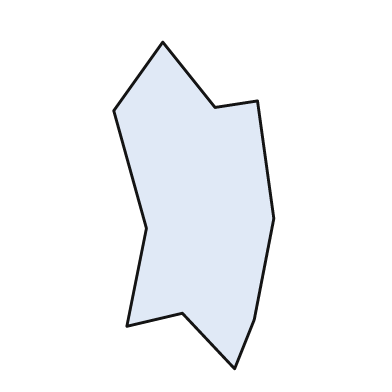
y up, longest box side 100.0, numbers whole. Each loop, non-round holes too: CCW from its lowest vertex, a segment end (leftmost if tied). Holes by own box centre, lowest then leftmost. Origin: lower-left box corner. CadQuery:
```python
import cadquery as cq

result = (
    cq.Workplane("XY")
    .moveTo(37.0, 0.0)
    .lineTo(43.0, 15.0)
    .lineTo(49.0, 46.0)
    .lineTo(44.0, 82.0)
    .lineTo(31.0, 80.0)
    .lineTo(15.0, 100.0)
    .lineTo(0.0, 79.0)
    .lineTo(10.0, 43.0)
    .lineTo(4.0, 13.0)
    .lineTo(21.0, 17.0)
    .close()
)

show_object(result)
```